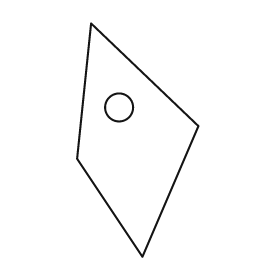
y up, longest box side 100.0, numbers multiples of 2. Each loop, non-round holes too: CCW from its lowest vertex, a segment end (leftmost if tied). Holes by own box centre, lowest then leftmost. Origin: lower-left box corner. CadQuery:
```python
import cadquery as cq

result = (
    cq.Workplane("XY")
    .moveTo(28.0, 0.0)
    .lineTo(52.0, 56.0)
    .lineTo(6.0, 100.0)
    .lineTo(0.0, 42.0)
    .close()
    .moveTo(18.0, 64.0)
    .circle(6.0)
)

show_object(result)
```